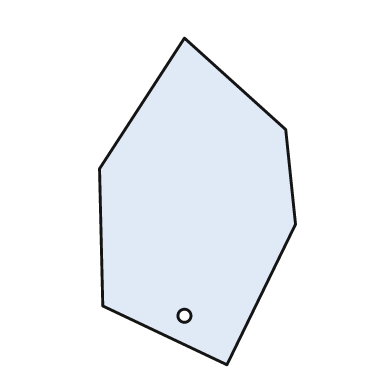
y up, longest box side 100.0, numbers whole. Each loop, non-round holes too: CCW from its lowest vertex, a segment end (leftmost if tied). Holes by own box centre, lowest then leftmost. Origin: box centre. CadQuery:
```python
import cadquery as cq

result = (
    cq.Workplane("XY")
    .moveTo(9.0, -50.0)
    .lineTo(30.0, -7.0)
    .lineTo(27.0, 22.0)
    .lineTo(-4.0, 50.0)
    .lineTo(-30.0, 10.0)
    .lineTo(-29.0, -32.0)
    .close()
    .moveTo(-4.0, -35.0)
    .circle(2.0)
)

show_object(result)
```